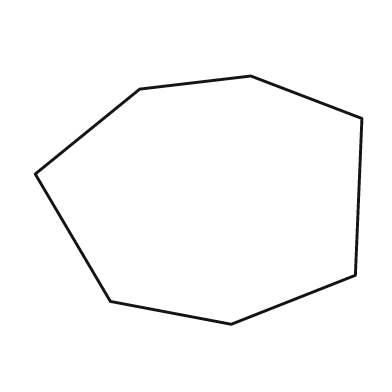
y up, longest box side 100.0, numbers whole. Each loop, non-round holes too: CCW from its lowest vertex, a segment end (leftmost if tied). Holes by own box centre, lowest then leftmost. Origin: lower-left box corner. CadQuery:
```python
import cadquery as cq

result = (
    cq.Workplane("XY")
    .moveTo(60.0, 0.0)
    .lineTo(98.0, 15.0)
    .lineTo(100.0, 63.0)
    .lineTo(66.0, 76.0)
    .lineTo(32.0, 72.0)
    .lineTo(0.0, 46.0)
    .lineTo(23.0, 7.0)
    .close()
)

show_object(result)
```